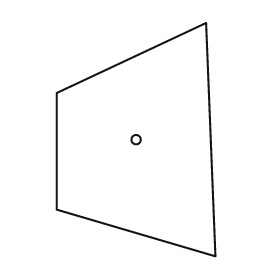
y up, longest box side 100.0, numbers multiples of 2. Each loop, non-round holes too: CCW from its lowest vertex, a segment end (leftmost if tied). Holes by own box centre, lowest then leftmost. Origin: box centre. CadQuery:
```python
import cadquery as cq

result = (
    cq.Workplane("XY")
    .moveTo(34.0, -50.0)
    .lineTo(30.0, 50.0)
    .lineTo(-34.0, 20.0)
    .lineTo(-34.0, -30.0)
    .close()
    .moveTo(0.0, 0.0)
    .circle(2.0)
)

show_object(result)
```